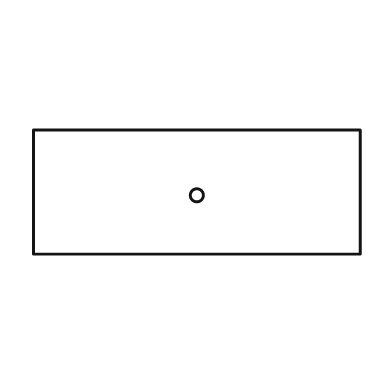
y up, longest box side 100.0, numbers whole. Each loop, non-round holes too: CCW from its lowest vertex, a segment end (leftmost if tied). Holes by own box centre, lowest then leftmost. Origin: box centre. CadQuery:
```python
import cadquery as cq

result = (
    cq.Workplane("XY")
    .moveTo(-50.0, -19.0)
    .lineTo(50.0, -19.0)
    .lineTo(50.0, 19.0)
    .lineTo(-50.0, 19.0)
    .close()
    .moveTo(0.0, -1.0)
    .circle(2.0)
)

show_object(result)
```